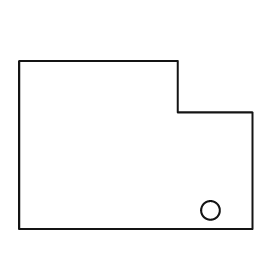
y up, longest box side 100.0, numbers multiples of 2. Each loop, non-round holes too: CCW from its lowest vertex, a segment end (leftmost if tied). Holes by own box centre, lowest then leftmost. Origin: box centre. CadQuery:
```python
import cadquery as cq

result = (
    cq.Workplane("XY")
    .moveTo(-50.0, -36.0)
    .lineTo(50.0, -36.0)
    .lineTo(50.0, 14.0)
    .lineTo(18.0, 14.0)
    .lineTo(18.0, 36.0)
    .lineTo(-50.0, 36.0)
    .close()
    .moveTo(32.0, -28.0)
    .circle(4.0)
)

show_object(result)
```